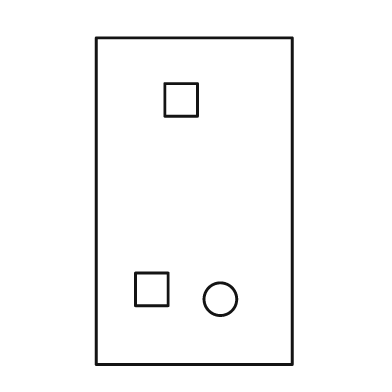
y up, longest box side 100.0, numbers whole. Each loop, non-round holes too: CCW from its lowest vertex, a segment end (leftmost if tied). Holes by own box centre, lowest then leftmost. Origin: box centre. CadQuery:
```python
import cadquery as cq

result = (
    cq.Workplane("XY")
    .moveTo(-30.0, -50.0)
    .lineTo(30.0, -50.0)
    .lineTo(30.0, 50.0)
    .lineTo(-30.0, 50.0)
    .close()
    .moveTo(8.0, -30.0)
    .circle(5.0)
    .moveTo(-18.0, -32.0)
    .lineTo(-8.0, -32.0)
    .lineTo(-8.0, -22.0)
    .lineTo(-18.0, -22.0)
    .close()
    .moveTo(-9.0, 26.0)
    .lineTo(1.0, 26.0)
    .lineTo(1.0, 36.0)
    .lineTo(-9.0, 36.0)
    .close()
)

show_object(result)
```